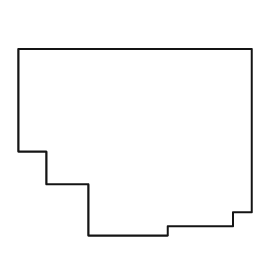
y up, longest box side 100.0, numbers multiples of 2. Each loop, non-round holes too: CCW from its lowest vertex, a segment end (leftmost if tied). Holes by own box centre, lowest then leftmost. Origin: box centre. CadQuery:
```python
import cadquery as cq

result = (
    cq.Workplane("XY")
    .moveTo(-20.0, -40.0)
    .lineTo(14.0, -40.0)
    .lineTo(14.0, -36.0)
    .lineTo(42.0, -36.0)
    .lineTo(42.0, -30.0)
    .lineTo(50.0, -30.0)
    .lineTo(50.0, 40.0)
    .lineTo(-50.0, 40.0)
    .lineTo(-50.0, -4.0)
    .lineTo(-38.0, -4.0)
    .lineTo(-38.0, -18.0)
    .lineTo(-20.0, -18.0)
    .close()
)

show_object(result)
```